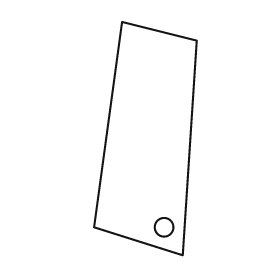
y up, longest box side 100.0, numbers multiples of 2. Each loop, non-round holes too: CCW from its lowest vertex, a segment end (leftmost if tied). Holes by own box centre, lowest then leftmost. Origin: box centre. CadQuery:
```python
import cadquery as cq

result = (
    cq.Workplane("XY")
    .moveTo(16.0, -50.0)
    .lineTo(22.0, 42.0)
    .lineTo(-10.0, 50.0)
    .lineTo(-22.0, -38.0)
    .close()
    .moveTo(8.0, -38.0)
    .circle(4.0)
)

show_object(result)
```